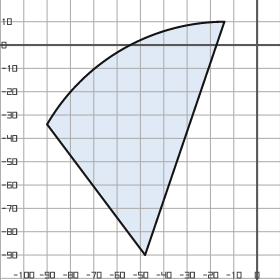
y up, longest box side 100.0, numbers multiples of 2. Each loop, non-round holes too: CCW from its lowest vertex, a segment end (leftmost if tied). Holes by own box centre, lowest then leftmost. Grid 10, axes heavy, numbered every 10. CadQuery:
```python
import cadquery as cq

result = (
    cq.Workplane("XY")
    .moveTo(-48.0, -90.0)
    .lineTo(-14.0, 10.0)
    .threePointArc((-58.0, -2.0), (-90.0, -34.0))
    .close()
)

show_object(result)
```